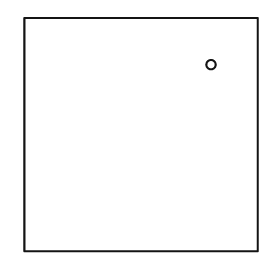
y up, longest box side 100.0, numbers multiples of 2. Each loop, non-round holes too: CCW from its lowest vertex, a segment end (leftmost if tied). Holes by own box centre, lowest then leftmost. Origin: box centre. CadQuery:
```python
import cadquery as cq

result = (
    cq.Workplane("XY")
    .moveTo(-50.0, -50.0)
    .lineTo(50.0, -50.0)
    .lineTo(50.0, 50.0)
    .lineTo(-50.0, 50.0)
    .close()
    .moveTo(30.0, 30.0)
    .circle(2.0)
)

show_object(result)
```